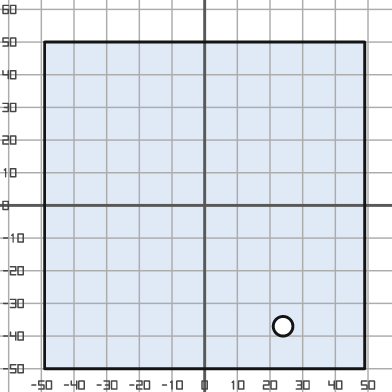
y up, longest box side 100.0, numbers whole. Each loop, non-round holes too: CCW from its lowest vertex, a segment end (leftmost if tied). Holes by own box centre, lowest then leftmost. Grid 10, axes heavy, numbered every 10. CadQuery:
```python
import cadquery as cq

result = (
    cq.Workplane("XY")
    .moveTo(-49.0, -50.0)
    .lineTo(49.0, -50.0)
    .lineTo(49.0, 50.0)
    .lineTo(-49.0, 50.0)
    .close()
    .moveTo(24.0, -37.0)
    .circle(3.0)
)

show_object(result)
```